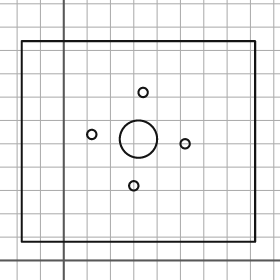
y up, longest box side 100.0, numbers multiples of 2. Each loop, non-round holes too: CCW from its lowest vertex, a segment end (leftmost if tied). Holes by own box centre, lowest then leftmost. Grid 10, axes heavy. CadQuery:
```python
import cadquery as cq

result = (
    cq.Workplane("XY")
    .moveTo(-18.0, 8.0)
    .lineTo(82.0, 8.0)
    .lineTo(82.0, 94.0)
    .lineTo(-18.0, 94.0)
    .close()
    .moveTo(30.0, 32.0)
    .circle(2.0)
    .moveTo(52.0, 50.0)
    .circle(2.0)
    .moveTo(32.0, 52.0)
    .circle(8.0)
    .moveTo(12.0, 54.0)
    .circle(2.0)
    .moveTo(34.0, 72.0)
    .circle(2.0)
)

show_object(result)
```